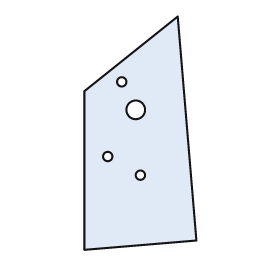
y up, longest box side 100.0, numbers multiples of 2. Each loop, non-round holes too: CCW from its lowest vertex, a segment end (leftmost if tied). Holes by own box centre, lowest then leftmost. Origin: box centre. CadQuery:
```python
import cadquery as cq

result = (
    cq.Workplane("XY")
    .moveTo(-24.0, -50.0)
    .lineTo(24.0, -46.0)
    .lineTo(16.0, 50.0)
    .lineTo(-24.0, 18.0)
    .close()
    .moveTo(0.0, -18.0)
    .circle(2.0)
    .moveTo(-14.0, -10.0)
    .circle(2.0)
    .moveTo(-2.0, 10.0)
    .circle(4.0)
    .moveTo(-8.0, 22.0)
    .circle(2.0)
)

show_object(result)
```